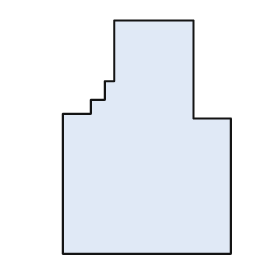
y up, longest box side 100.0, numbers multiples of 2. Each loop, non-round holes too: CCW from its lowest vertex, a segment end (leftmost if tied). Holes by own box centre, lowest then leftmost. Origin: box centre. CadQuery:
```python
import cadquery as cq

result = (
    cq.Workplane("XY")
    .moveTo(-36.0, -50.0)
    .lineTo(36.0, -50.0)
    .lineTo(36.0, 8.0)
    .lineTo(20.0, 8.0)
    .lineTo(20.0, 50.0)
    .lineTo(-14.0, 50.0)
    .lineTo(-14.0, 24.0)
    .lineTo(-18.0, 24.0)
    .lineTo(-18.0, 16.0)
    .lineTo(-24.0, 16.0)
    .lineTo(-24.0, 10.0)
    .lineTo(-36.0, 10.0)
    .close()
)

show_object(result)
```